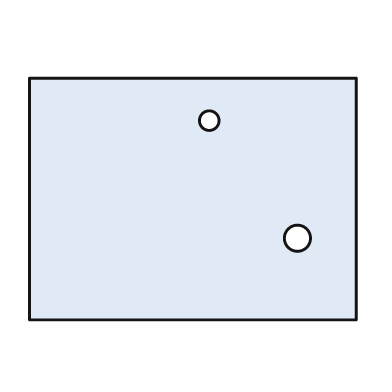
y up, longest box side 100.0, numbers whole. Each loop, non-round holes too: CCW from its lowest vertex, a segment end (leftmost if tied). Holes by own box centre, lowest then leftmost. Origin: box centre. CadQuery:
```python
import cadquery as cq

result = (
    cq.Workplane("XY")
    .moveTo(-50.0, -37.0)
    .lineTo(50.0, -37.0)
    .lineTo(50.0, 37.0)
    .lineTo(-50.0, 37.0)
    .close()
    .moveTo(32.0, -12.0)
    .circle(4.0)
    .moveTo(5.0, 24.0)
    .circle(3.0)
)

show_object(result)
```